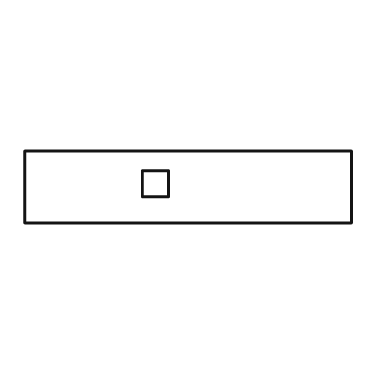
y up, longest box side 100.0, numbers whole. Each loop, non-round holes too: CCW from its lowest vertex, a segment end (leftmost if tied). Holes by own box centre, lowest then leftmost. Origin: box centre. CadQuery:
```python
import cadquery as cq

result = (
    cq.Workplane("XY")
    .moveTo(-50.0, -11.0)
    .lineTo(50.0, -11.0)
    .lineTo(50.0, 11.0)
    .lineTo(-50.0, 11.0)
    .close()
    .moveTo(-14.0, -3.0)
    .lineTo(-6.0, -3.0)
    .lineTo(-6.0, 5.0)
    .lineTo(-14.0, 5.0)
    .close()
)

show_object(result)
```